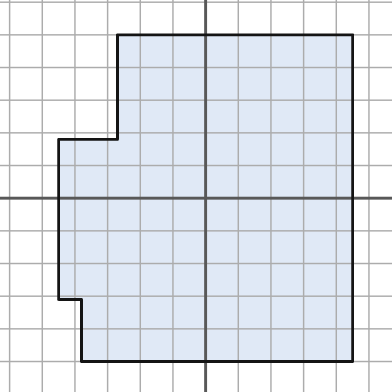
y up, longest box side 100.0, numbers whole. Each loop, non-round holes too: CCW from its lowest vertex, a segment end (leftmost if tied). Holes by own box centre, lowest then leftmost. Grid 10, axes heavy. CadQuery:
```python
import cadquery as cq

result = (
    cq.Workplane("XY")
    .moveTo(-38.0, -50.0)
    .lineTo(45.0, -50.0)
    .lineTo(45.0, 50.0)
    .lineTo(-27.0, 50.0)
    .lineTo(-27.0, 18.0)
    .lineTo(-45.0, 18.0)
    .lineTo(-45.0, -31.0)
    .lineTo(-38.0, -31.0)
    .close()
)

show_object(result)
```